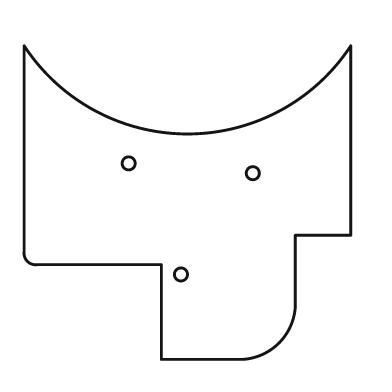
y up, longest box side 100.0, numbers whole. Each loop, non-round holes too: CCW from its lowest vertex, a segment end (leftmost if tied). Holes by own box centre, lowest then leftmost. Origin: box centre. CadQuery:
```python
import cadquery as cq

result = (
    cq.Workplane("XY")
    .moveTo(-8.0, -48.0)
    .lineTo(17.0, -48.0)
    .threePointArc((28.0, -43.0), (33.0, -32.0))
    .lineTo(33.0, -10.0)
    .lineTo(50.0, -10.0)
    .lineTo(50.0, 48.0)
    .threePointArc((0.0, 21.0), (-50.0, 48.0))
    .lineTo(-50.0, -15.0)
    .threePointArc((-49.0, -18.0), (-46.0, -19.0))
    .lineTo(-8.0, -19.0)
    .close()
    .moveTo(-2.0, -22.0)
    .circle(2.0)
    .moveTo(20.0, 9.0)
    .circle(2.0)
    .moveTo(-18.0, 12.0)
    .circle(2.0)
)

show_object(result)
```